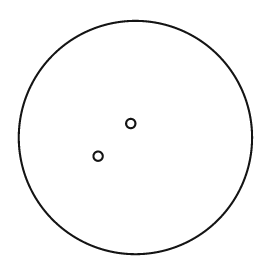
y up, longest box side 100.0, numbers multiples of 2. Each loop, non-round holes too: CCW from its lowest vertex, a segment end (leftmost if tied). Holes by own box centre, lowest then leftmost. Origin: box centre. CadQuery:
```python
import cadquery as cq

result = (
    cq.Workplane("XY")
    .moveTo(0.0, 0.0)
    .circle(50.0)
    .moveTo(-16.0, -8.0)
    .circle(2.0)
    .moveTo(-2.0, 6.0)
    .circle(2.0)
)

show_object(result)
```